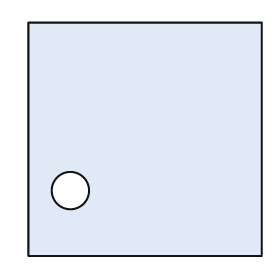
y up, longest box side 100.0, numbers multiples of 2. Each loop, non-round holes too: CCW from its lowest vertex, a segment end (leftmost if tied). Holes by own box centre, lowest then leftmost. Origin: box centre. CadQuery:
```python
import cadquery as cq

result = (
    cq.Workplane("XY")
    .moveTo(-50.0, -50.0)
    .lineTo(50.0, -50.0)
    .lineTo(50.0, 50.0)
    .lineTo(-50.0, 50.0)
    .close()
    .moveTo(-32.0, -22.0)
    .circle(8.0)
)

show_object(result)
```